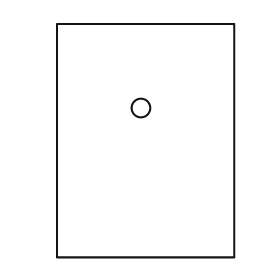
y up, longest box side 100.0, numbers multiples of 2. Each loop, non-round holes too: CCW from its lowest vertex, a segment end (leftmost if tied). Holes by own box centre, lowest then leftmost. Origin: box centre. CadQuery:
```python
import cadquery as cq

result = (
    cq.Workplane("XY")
    .moveTo(-38.0, -50.0)
    .lineTo(38.0, -50.0)
    .lineTo(38.0, 50.0)
    .lineTo(-38.0, 50.0)
    .close()
    .moveTo(-2.0, 14.0)
    .circle(4.0)
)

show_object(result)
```